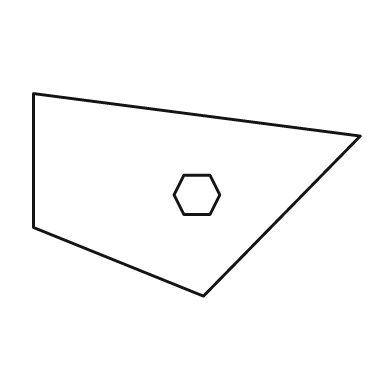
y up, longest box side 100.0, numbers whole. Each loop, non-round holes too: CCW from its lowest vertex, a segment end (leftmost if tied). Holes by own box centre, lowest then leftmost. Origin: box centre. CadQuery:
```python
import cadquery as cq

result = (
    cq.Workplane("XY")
    .moveTo(2.0, -31.0)
    .lineTo(50.0, 18.0)
    .lineTo(-50.0, 31.0)
    .lineTo(-50.0, -10.0)
    .close()
    .moveTo(-4.0, -6.0)
    .lineTo(4.0, -6.0)
    .lineTo(7.0, 0.0)
    .lineTo(4.0, 6.0)
    .lineTo(-4.0, 6.0)
    .lineTo(-7.0, 0.0)
    .close()
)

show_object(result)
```